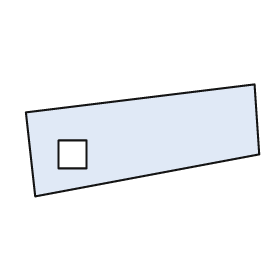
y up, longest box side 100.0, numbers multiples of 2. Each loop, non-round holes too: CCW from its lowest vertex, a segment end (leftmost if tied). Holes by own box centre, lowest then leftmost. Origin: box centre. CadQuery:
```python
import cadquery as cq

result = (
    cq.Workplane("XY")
    .moveTo(-46.0, -24.0)
    .lineTo(50.0, -6.0)
    .lineTo(48.0, 24.0)
    .lineTo(-50.0, 12.0)
    .close()
    .moveTo(-36.0, -12.0)
    .lineTo(-24.0, -12.0)
    .lineTo(-24.0, 0.0)
    .lineTo(-36.0, 0.0)
    .close()
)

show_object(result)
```